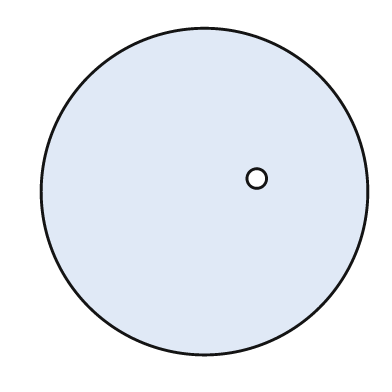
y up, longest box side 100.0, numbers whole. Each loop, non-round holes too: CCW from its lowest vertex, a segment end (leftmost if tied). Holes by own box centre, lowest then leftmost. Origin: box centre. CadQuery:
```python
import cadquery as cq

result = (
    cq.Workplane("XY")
    .moveTo(0.0, 0.0)
    .circle(50.0)
    .moveTo(16.0, 4.0)
    .circle(3.0)
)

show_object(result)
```